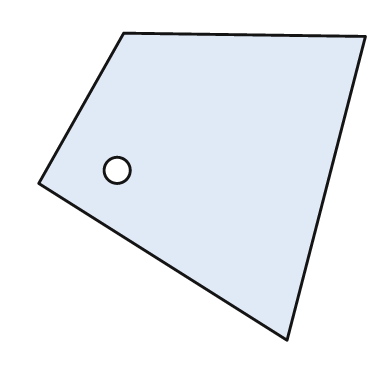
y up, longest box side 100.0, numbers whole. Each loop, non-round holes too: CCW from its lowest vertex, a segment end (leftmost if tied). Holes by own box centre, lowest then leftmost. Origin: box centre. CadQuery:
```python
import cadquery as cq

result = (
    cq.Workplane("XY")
    .moveTo(26.0, -47.0)
    .lineTo(50.0, 46.0)
    .lineTo(-24.0, 47.0)
    .lineTo(-50.0, 1.0)
    .close()
    .moveTo(-26.0, 5.0)
    .circle(4.0)
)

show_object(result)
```